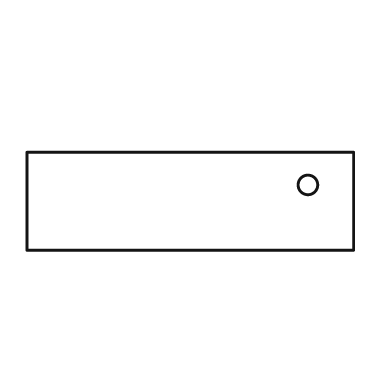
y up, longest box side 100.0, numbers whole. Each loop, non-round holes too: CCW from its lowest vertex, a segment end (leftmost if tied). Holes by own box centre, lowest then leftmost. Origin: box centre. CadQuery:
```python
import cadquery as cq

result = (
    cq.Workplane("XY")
    .moveTo(-50.0, -15.0)
    .lineTo(50.0, -15.0)
    .lineTo(50.0, 15.0)
    .lineTo(-50.0, 15.0)
    .close()
    .moveTo(36.0, 5.0)
    .circle(3.0)
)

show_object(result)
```